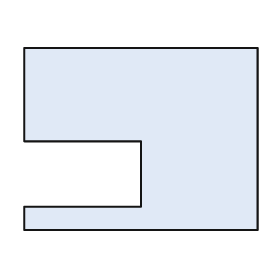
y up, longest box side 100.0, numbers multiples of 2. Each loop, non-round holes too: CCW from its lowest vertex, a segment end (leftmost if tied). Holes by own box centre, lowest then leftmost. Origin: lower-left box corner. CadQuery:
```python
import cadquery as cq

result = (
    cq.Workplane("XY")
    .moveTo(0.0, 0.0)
    .lineTo(100.0, 0.0)
    .lineTo(100.0, 78.0)
    .lineTo(0.0, 78.0)
    .lineTo(0.0, 38.0)
    .lineTo(50.0, 38.0)
    .lineTo(50.0, 10.0)
    .lineTo(0.0, 10.0)
    .close()
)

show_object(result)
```